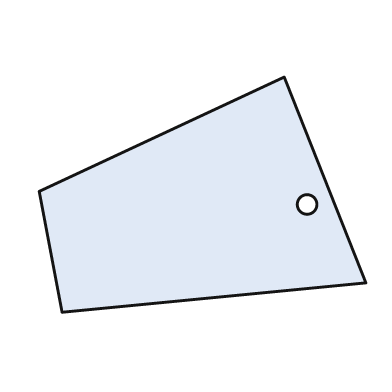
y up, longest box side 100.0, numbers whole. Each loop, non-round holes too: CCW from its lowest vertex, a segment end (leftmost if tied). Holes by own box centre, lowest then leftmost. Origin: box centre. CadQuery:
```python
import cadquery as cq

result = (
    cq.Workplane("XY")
    .moveTo(-43.0, -36.0)
    .lineTo(50.0, -27.0)
    .lineTo(25.0, 36.0)
    .lineTo(-50.0, 1.0)
    .close()
    .moveTo(32.0, -3.0)
    .circle(3.0)
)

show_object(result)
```